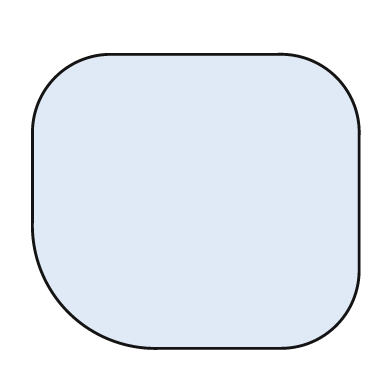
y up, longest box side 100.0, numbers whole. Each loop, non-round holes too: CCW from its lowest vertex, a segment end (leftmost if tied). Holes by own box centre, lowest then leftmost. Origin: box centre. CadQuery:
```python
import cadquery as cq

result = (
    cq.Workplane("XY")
    .moveTo(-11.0, -45.0)
    .lineTo(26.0, -45.0)
    .threePointArc((43.0, -38.0), (50.0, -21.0))
    .lineTo(50.0, 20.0)
    .threePointArc((43.0, 38.0), (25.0, 45.0))
    .lineTo(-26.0, 45.0)
    .threePointArc((-43.0, 38.0), (-50.0, 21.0))
    .lineTo(-50.0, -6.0)
    .threePointArc((-39.0, -34.0), (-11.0, -45.0))
    .close()
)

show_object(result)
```